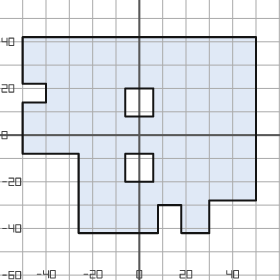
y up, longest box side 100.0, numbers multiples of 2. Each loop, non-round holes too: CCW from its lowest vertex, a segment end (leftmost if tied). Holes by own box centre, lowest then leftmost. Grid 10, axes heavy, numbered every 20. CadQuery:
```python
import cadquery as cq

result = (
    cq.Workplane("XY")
    .moveTo(-26.0, -42.0)
    .lineTo(8.0, -42.0)
    .lineTo(8.0, -30.0)
    .lineTo(18.0, -30.0)
    .lineTo(18.0, -42.0)
    .lineTo(30.0, -42.0)
    .lineTo(30.0, -28.0)
    .lineTo(50.0, -28.0)
    .lineTo(50.0, 42.0)
    .lineTo(-50.0, 42.0)
    .lineTo(-50.0, 22.0)
    .lineTo(-40.0, 22.0)
    .lineTo(-40.0, 14.0)
    .lineTo(-50.0, 14.0)
    .lineTo(-50.0, -8.0)
    .lineTo(-26.0, -8.0)
    .close()
    .moveTo(-6.0, -20.0)
    .lineTo(6.0, -20.0)
    .lineTo(6.0, -8.0)
    .lineTo(-6.0, -8.0)
    .close()
    .moveTo(-6.0, 8.0)
    .lineTo(6.0, 8.0)
    .lineTo(6.0, 20.0)
    .lineTo(-6.0, 20.0)
    .close()
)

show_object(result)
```